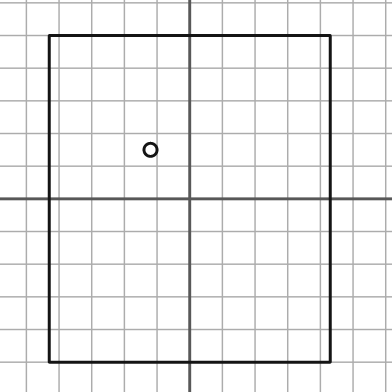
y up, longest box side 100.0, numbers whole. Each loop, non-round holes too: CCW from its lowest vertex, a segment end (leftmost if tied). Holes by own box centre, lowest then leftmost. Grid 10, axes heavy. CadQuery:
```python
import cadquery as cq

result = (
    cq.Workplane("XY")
    .moveTo(-43.0, -50.0)
    .lineTo(43.0, -50.0)
    .lineTo(43.0, 50.0)
    .lineTo(-43.0, 50.0)
    .close()
    .moveTo(-12.0, 15.0)
    .circle(2.0)
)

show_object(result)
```